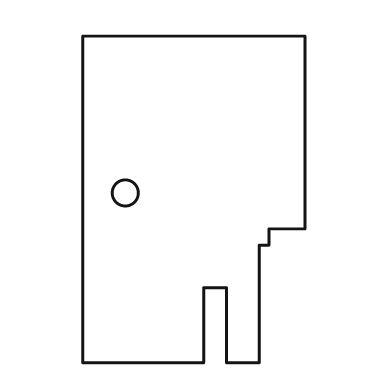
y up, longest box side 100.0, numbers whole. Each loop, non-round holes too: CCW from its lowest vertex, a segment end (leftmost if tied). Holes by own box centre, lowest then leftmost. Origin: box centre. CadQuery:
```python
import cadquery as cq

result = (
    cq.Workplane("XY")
    .moveTo(-34.0, -50.0)
    .lineTo(3.0, -50.0)
    .lineTo(3.0, -27.0)
    .lineTo(10.0, -27.0)
    .lineTo(10.0, -50.0)
    .lineTo(20.0, -50.0)
    .lineTo(20.0, -14.0)
    .lineTo(23.0, -14.0)
    .lineTo(23.0, -9.0)
    .lineTo(34.0, -9.0)
    .lineTo(34.0, 50.0)
    .lineTo(-34.0, 50.0)
    .close()
    .moveTo(-21.0, 2.0)
    .circle(4.0)
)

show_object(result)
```